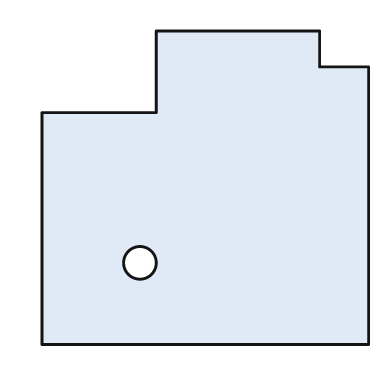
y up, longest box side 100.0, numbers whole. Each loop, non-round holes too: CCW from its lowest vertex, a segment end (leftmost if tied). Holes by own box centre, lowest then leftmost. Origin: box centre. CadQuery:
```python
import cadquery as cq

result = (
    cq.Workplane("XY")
    .moveTo(-50.0, -48.0)
    .lineTo(50.0, -48.0)
    .lineTo(50.0, 37.0)
    .lineTo(35.0, 37.0)
    .lineTo(35.0, 48.0)
    .lineTo(-15.0, 48.0)
    .lineTo(-15.0, 23.0)
    .lineTo(-50.0, 23.0)
    .close()
    .moveTo(-20.0, -23.0)
    .circle(5.0)
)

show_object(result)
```